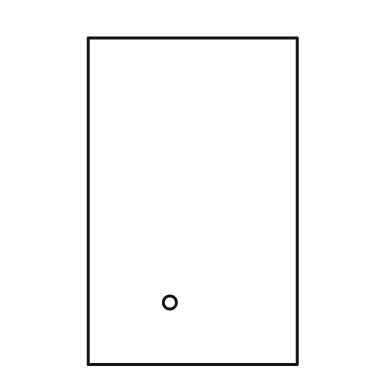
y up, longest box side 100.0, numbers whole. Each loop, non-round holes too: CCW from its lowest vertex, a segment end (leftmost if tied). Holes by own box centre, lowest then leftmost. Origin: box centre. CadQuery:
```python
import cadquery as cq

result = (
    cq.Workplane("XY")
    .moveTo(-32.0, -50.0)
    .lineTo(32.0, -50.0)
    .lineTo(32.0, 50.0)
    .lineTo(-32.0, 50.0)
    .close()
    .moveTo(-7.0, -31.0)
    .circle(2.0)
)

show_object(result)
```